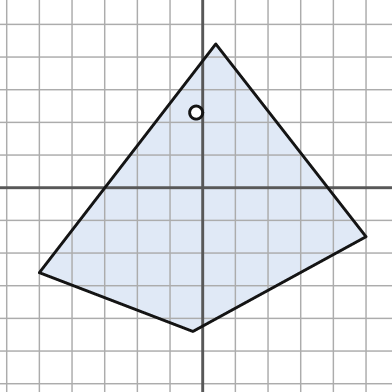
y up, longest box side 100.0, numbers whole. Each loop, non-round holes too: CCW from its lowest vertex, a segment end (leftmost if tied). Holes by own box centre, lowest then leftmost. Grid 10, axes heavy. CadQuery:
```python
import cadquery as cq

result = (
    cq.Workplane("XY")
    .moveTo(-3.0, -44.0)
    .lineTo(50.0, -15.0)
    .lineTo(4.0, 44.0)
    .lineTo(-50.0, -26.0)
    .close()
    .moveTo(-2.0, 23.0)
    .circle(2.0)
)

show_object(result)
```